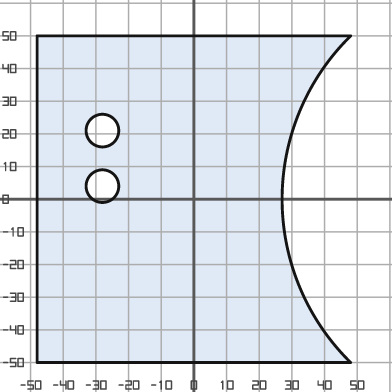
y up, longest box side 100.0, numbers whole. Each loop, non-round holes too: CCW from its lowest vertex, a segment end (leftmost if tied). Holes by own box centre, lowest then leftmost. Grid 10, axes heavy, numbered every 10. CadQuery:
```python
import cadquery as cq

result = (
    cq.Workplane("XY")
    .moveTo(-48.0, -50.0)
    .lineTo(48.0, -50.0)
    .threePointArc((27.0, 0.0), (48.0, 50.0))
    .lineTo(-48.0, 50.0)
    .close()
    .moveTo(-28.0, 4.0)
    .circle(5.0)
    .moveTo(-28.0, 21.0)
    .circle(5.0)
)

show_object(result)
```